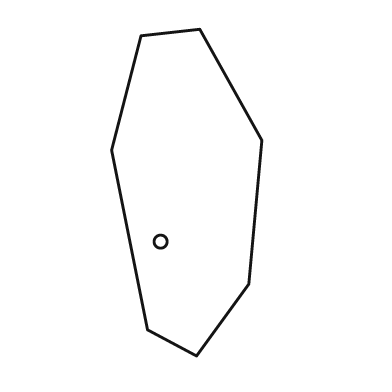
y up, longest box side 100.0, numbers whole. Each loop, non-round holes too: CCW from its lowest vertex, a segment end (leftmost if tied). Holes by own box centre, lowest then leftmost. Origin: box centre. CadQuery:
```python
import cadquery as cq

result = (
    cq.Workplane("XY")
    .moveTo(3.0, -50.0)
    .lineTo(19.0, -28.0)
    .lineTo(23.0, 16.0)
    .lineTo(4.0, 50.0)
    .lineTo(-14.0, 48.0)
    .lineTo(-23.0, 13.0)
    .lineTo(-12.0, -42.0)
    .close()
    .moveTo(-8.0, -15.0)
    .circle(2.0)
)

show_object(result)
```